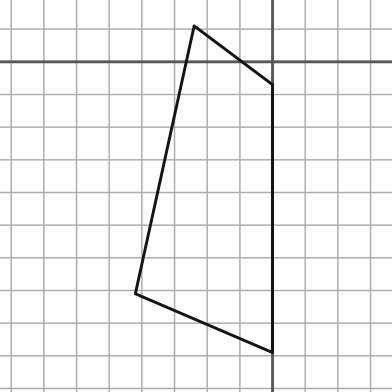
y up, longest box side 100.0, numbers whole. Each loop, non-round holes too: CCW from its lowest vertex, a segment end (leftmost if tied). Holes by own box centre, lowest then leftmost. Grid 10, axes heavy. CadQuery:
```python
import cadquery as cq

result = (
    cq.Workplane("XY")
    .moveTo(0.0, -89.0)
    .lineTo(0.0, -7.0)
    .lineTo(-24.0, 11.0)
    .lineTo(-42.0, -71.0)
    .close()
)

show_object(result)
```